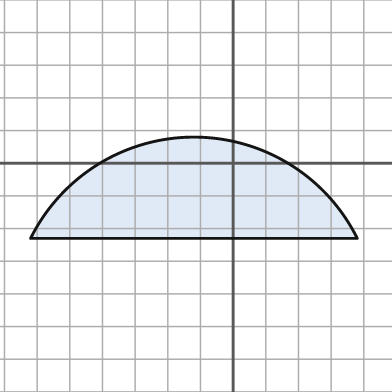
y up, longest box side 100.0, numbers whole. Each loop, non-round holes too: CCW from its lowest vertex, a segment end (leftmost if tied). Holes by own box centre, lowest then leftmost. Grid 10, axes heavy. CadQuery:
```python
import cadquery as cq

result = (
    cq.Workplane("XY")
    .moveTo(-62.0, -23.0)
    .lineTo(38.0, -23.0)
    .threePointArc((-12.0, 8.0), (-62.0, -23.0))
    .close()
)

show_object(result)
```